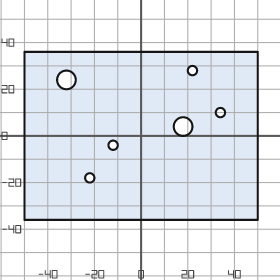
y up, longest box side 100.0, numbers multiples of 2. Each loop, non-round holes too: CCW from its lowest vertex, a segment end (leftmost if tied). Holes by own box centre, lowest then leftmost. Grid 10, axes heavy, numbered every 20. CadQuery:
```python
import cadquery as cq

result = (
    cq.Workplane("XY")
    .moveTo(-50.0, -36.0)
    .lineTo(50.0, -36.0)
    .lineTo(50.0, 36.0)
    .lineTo(-50.0, 36.0)
    .close()
    .moveTo(-22.0, -18.0)
    .circle(2.0)
    .moveTo(-12.0, -4.0)
    .circle(2.0)
    .moveTo(18.0, 4.0)
    .circle(4.0)
    .moveTo(34.0, 10.0)
    .circle(2.0)
    .moveTo(-32.0, 24.0)
    .circle(4.0)
    .moveTo(22.0, 28.0)
    .circle(2.0)
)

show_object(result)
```